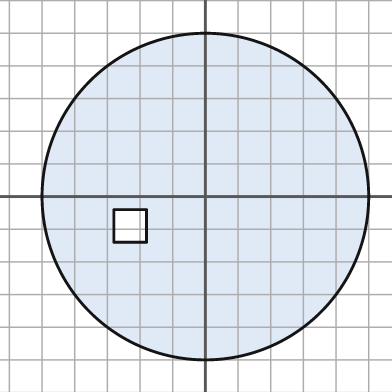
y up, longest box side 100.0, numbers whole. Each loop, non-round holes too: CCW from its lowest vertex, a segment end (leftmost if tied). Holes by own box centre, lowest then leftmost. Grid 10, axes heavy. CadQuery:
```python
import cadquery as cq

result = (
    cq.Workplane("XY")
    .moveTo(0.0, 0.0)
    .circle(50.0)
    .moveTo(-28.0, -14.0)
    .lineTo(-18.0, -14.0)
    .lineTo(-18.0, -4.0)
    .lineTo(-28.0, -4.0)
    .close()
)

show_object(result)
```